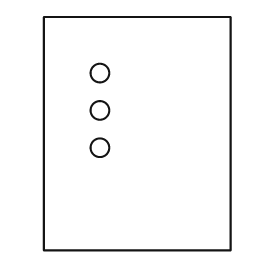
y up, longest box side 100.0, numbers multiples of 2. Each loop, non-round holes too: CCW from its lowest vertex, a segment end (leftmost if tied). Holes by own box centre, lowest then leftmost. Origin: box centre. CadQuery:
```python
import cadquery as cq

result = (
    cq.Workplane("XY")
    .moveTo(-40.0, -50.0)
    .lineTo(40.0, -50.0)
    .lineTo(40.0, 50.0)
    .lineTo(-40.0, 50.0)
    .close()
    .moveTo(-16.0, -6.0)
    .circle(4.0)
    .moveTo(-16.0, 10.0)
    .circle(4.0)
    .moveTo(-16.0, 26.0)
    .circle(4.0)
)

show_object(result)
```